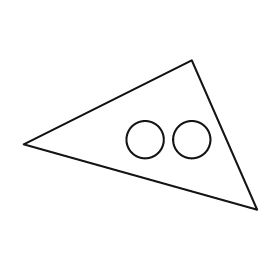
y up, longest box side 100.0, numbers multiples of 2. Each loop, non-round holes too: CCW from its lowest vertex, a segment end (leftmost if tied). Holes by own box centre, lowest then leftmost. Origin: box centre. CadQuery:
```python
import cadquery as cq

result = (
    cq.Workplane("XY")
    .moveTo(50.0, -32.0)
    .lineTo(22.0, 32.0)
    .lineTo(-50.0, -4.0)
    .close()
    .moveTo(2.0, -2.0)
    .circle(8.0)
    .moveTo(22.0, -2.0)
    .circle(8.0)
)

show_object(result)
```